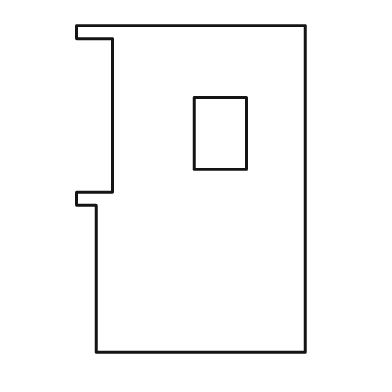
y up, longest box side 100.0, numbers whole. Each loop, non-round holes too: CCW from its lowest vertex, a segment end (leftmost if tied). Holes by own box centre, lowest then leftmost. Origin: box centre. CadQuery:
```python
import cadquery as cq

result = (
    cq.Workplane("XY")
    .moveTo(-29.0, -50.0)
    .lineTo(35.0, -50.0)
    .lineTo(35.0, 50.0)
    .lineTo(-35.0, 50.0)
    .lineTo(-35.0, 46.0)
    .lineTo(-24.0, 46.0)
    .lineTo(-24.0, -1.0)
    .lineTo(-35.0, -1.0)
    .lineTo(-35.0, -5.0)
    .lineTo(-29.0, -5.0)
    .close()
    .moveTo(1.0, 6.0)
    .lineTo(17.0, 6.0)
    .lineTo(17.0, 28.0)
    .lineTo(1.0, 28.0)
    .close()
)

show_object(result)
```